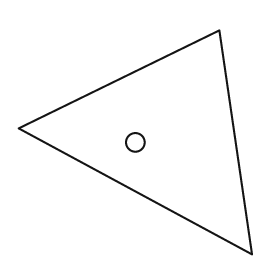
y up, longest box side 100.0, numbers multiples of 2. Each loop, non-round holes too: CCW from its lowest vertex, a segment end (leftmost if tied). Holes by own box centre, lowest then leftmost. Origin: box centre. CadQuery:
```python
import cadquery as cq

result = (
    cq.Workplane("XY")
    .moveTo(50.0, -48.0)
    .lineTo(36.0, 48.0)
    .lineTo(-50.0, 6.0)
    .close()
    .moveTo(0.0, 0.0)
    .circle(4.0)
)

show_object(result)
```